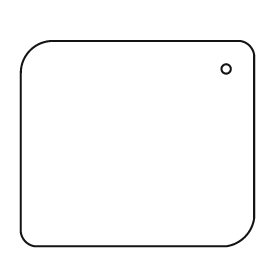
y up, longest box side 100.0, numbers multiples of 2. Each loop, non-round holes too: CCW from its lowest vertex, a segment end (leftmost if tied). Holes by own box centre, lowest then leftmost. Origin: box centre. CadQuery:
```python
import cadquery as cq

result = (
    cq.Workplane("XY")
    .moveTo(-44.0, -44.0)
    .lineTo(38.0, -44.0)
    .threePointArc((46.0, -40.0), (50.0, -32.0))
    .lineTo(50.0, 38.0)
    .threePointArc((48.0, 42.0), (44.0, 44.0))
    .lineTo(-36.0, 44.0)
    .threePointArc((-46.0, 40.0), (-50.0, 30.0))
    .lineTo(-50.0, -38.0)
    .threePointArc((-48.0, -42.0), (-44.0, -44.0))
    .close()
    .moveTo(38.0, 32.0)
    .circle(2.0)
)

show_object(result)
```